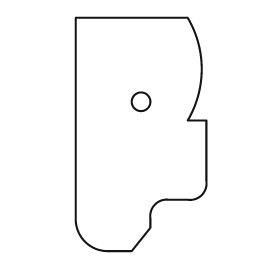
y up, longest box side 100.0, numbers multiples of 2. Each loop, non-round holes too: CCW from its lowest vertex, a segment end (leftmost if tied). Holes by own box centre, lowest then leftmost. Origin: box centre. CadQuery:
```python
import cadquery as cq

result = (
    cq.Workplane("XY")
    .moveTo(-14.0, -50.0)
    .lineTo(-4.0, -50.0)
    .lineTo(4.0, -40.0)
    .lineTo(4.0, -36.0)
    .threePointArc((6.0, -30.0), (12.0, -28.0))
    .lineTo(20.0, -28.0)
    .threePointArc((26.0, -26.0), (28.0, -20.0))
    .lineTo(28.0, 6.0)
    .lineTo(20.0, 6.0)
    .threePointArc((26.0, 28.0), (20.0, 50.0))
    .lineTo(-28.0, 50.0)
    .lineTo(-28.0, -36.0)
    .threePointArc((-24.0, -46.0), (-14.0, -50.0))
    .close()
    .moveTo(0.0, 14.0)
    .circle(4.0)
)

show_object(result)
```